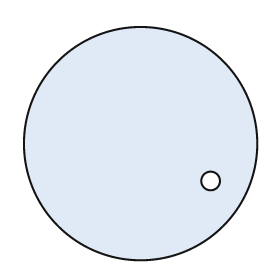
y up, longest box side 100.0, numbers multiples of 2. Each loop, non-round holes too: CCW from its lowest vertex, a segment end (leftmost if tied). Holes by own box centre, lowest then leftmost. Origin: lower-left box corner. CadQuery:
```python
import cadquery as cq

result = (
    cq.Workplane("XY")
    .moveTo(50.0, 50.0)
    .circle(50.0)
    .moveTo(80.0, 34.0)
    .circle(4.0)
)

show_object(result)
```